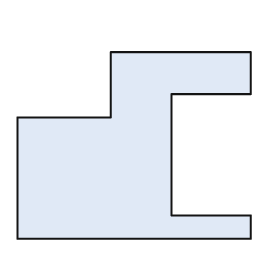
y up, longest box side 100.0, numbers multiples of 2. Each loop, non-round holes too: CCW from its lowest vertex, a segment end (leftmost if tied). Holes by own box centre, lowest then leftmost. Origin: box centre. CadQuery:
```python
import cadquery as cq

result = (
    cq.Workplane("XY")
    .moveTo(-50.0, -40.0)
    .lineTo(50.0, -40.0)
    .lineTo(50.0, -30.0)
    .lineTo(16.0, -30.0)
    .lineTo(16.0, 22.0)
    .lineTo(50.0, 22.0)
    .lineTo(50.0, 40.0)
    .lineTo(-10.0, 40.0)
    .lineTo(-10.0, 12.0)
    .lineTo(-50.0, 12.0)
    .close()
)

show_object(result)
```